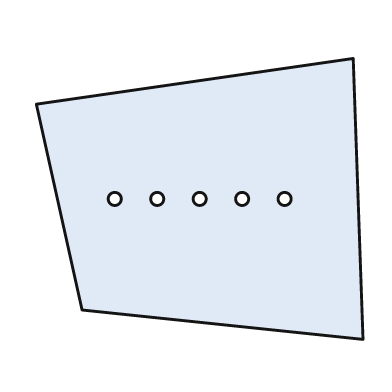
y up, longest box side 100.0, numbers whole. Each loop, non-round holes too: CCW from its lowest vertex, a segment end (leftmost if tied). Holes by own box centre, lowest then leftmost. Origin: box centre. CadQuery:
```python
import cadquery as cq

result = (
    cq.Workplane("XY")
    .moveTo(50.0, -43.0)
    .lineTo(47.0, 43.0)
    .lineTo(-50.0, 29.0)
    .lineTo(-36.0, -34.0)
    .close()
    .moveTo(-26.0, 0.0)
    .circle(2.0)
    .moveTo(-13.0, 0.0)
    .circle(2.0)
    .moveTo(0.0, 0.0)
    .circle(2.0)
    .moveTo(13.0, 0.0)
    .circle(2.0)
    .moveTo(26.0, 0.0)
    .circle(2.0)
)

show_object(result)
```